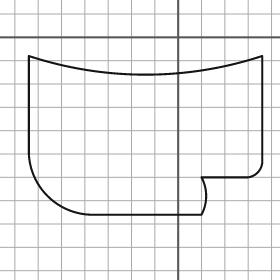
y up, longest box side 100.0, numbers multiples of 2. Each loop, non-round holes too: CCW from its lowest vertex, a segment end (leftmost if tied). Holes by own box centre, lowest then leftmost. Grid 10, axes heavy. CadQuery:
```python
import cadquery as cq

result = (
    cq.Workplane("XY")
    .moveTo(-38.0, -76.0)
    .lineTo(10.0, -76.0)
    .threePointArc((12.0, -68.0), (10.0, -60.0))
    .lineTo(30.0, -60.0)
    .threePointArc((34.0, -58.0), (36.0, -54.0))
    .lineTo(36.0, -8.0)
    .threePointArc((-14.0, -16.0), (-64.0, -8.0))
    .lineTo(-64.0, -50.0)
    .threePointArc((-56.0, -68.0), (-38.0, -76.0))
    .close()
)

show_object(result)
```